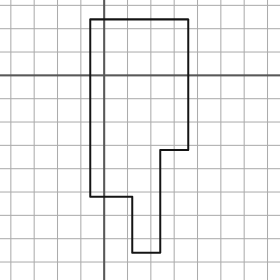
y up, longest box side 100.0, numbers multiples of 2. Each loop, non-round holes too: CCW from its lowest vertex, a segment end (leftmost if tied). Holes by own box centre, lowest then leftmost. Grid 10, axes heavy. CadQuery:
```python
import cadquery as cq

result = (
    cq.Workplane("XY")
    .moveTo(12.0, -76.0)
    .lineTo(24.0, -76.0)
    .lineTo(24.0, -32.0)
    .lineTo(36.0, -32.0)
    .lineTo(36.0, 24.0)
    .lineTo(-6.0, 24.0)
    .lineTo(-6.0, -52.0)
    .lineTo(12.0, -52.0)
    .close()
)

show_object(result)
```